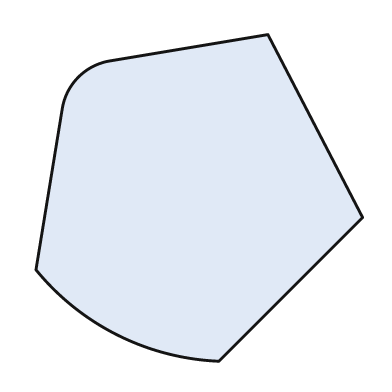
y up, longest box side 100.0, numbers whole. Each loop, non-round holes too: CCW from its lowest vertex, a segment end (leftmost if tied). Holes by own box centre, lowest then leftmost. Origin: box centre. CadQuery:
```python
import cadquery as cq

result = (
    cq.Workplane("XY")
    .moveTo(6.0, -50.0)
    .lineTo(50.0, -6.0)
    .lineTo(21.0, 50.0)
    .lineTo(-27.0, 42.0)
    .threePointArc((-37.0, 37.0), (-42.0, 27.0))
    .lineTo(-50.0, -22.0)
    .threePointArc((-25.0, -42.0), (6.0, -50.0))
    .close()
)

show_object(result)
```